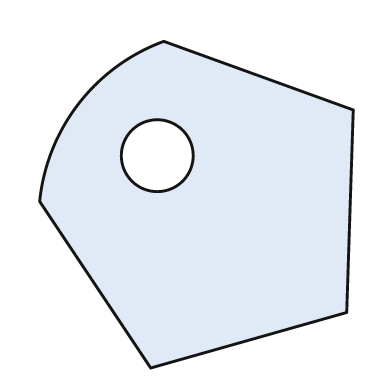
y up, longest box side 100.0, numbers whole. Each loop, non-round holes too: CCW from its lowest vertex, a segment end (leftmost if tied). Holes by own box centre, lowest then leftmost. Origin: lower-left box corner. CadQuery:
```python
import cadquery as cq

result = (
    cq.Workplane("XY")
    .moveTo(34.0, 0.0)
    .lineTo(94.0, 17.0)
    .lineTo(96.0, 79.0)
    .lineTo(38.0, 100.0)
    .threePointArc((12.0, 81.0), (0.0, 51.0))
    .close()
    .moveTo(36.0, 65.0)
    .circle(11.0)
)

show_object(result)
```